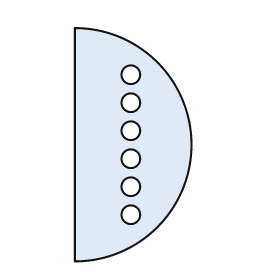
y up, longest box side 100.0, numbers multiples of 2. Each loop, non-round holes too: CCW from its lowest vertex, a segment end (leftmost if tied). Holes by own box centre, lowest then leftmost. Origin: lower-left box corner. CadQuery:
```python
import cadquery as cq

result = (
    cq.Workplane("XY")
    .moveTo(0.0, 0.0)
    .threePointArc((50.0, 50.0), (0.0, 100.0))
    .close()
    .moveTo(24.0, 20.0)
    .circle(4.0)
    .moveTo(24.0, 32.0)
    .circle(4.0)
    .moveTo(24.0, 44.0)
    .circle(4.0)
    .moveTo(24.0, 56.0)
    .circle(4.0)
    .moveTo(24.0, 68.0)
    .circle(4.0)
    .moveTo(24.0, 80.0)
    .circle(4.0)
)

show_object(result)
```